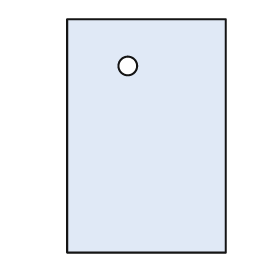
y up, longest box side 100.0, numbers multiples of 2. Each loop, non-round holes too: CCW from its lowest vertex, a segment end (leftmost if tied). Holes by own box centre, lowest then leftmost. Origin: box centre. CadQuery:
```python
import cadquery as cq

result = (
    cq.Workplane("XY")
    .moveTo(-34.0, -50.0)
    .lineTo(34.0, -50.0)
    .lineTo(34.0, 50.0)
    .lineTo(-34.0, 50.0)
    .close()
    .moveTo(-8.0, 30.0)
    .circle(4.0)
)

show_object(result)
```